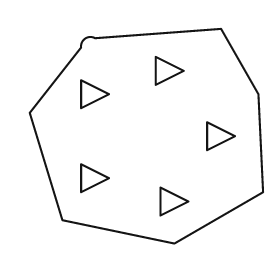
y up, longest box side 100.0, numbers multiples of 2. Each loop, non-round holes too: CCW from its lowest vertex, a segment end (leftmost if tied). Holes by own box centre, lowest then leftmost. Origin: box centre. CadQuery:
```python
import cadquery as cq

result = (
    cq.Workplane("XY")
    .moveTo(12.0, -46.0)
    .lineTo(50.0, -24.0)
    .lineTo(48.0, 18.0)
    .lineTo(32.0, 46.0)
    .lineTo(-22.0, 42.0)
    .threePointArc((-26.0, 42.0), (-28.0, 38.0))
    .lineTo(-50.0, 10.0)
    .lineTo(-36.0, -36.0)
    .close()
    .moveTo(6.0, -34.0)
    .lineTo(18.0, -28.0)
    .lineTo(6.0, -22.0)
    .close()
    .moveTo(-28.0, -24.0)
    .lineTo(-16.0, -18.0)
    .lineTo(-28.0, -12.0)
    .close()
    .moveTo(26.0, -6.0)
    .lineTo(38.0, 0.0)
    .lineTo(26.0, 6.0)
    .close()
    .moveTo(-28.0, 12.0)
    .lineTo(-16.0, 18.0)
    .lineTo(-28.0, 24.0)
    .close()
    .moveTo(4.0, 22.0)
    .lineTo(16.0, 28.0)
    .lineTo(4.0, 34.0)
    .close()
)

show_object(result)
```